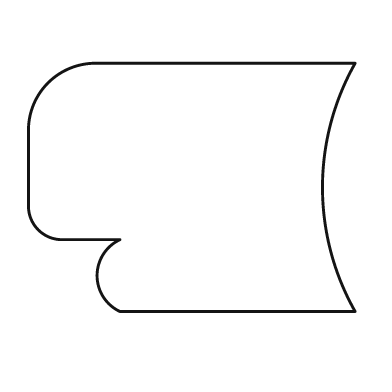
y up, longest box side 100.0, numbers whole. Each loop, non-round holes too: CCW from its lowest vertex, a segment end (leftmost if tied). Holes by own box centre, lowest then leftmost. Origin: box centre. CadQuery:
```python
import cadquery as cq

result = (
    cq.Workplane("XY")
    .moveTo(-22.0, -38.0)
    .lineTo(50.0, -38.0)
    .threePointArc((40.0, 0.0), (50.0, 38.0))
    .lineTo(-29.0, 38.0)
    .threePointArc((-44.0, 32.0), (-50.0, 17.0))
    .lineTo(-50.0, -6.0)
    .threePointArc((-47.0, -13.0), (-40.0, -16.0))
    .lineTo(-22.0, -16.0)
    .threePointArc((-29.0, -27.0), (-22.0, -38.0))
    .close()
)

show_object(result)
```